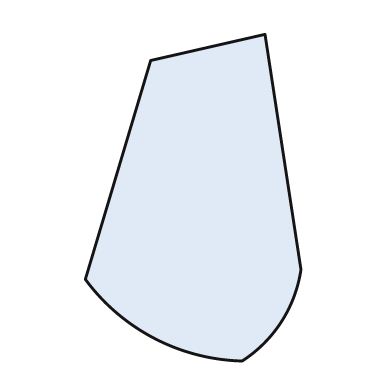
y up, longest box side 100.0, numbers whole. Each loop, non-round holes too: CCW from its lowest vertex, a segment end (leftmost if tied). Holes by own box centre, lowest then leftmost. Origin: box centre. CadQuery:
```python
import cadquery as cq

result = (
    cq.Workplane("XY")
    .moveTo(15.0, -50.0)
    .threePointArc((27.0, -38.0), (33.0, -22.0))
    .lineTo(22.0, 50.0)
    .lineTo(-13.0, 42.0)
    .lineTo(-33.0, -25.0)
    .threePointArc((-12.0, -43.0), (15.0, -50.0))
    .close()
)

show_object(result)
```